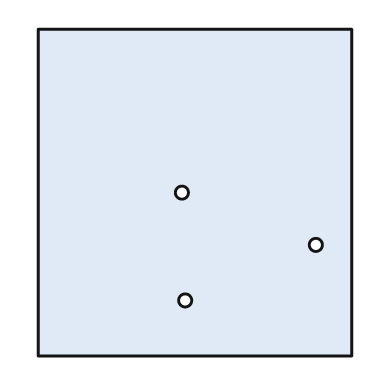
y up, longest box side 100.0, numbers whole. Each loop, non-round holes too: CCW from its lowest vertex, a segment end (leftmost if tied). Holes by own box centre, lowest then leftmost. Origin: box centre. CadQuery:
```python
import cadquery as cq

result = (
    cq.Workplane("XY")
    .moveTo(-48.0, -50.0)
    .lineTo(48.0, -50.0)
    .lineTo(48.0, 50.0)
    .lineTo(-48.0, 50.0)
    .close()
    .moveTo(-3.0, -33.0)
    .circle(2.0)
    .moveTo(37.0, -16.0)
    .circle(2.0)
    .moveTo(-4.0, 0.0)
    .circle(2.0)
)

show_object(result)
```